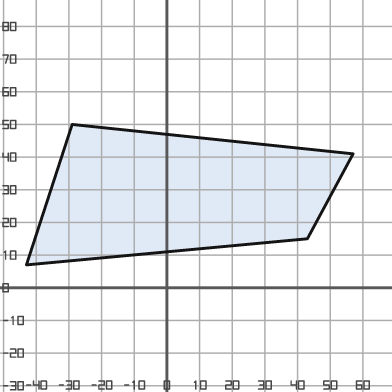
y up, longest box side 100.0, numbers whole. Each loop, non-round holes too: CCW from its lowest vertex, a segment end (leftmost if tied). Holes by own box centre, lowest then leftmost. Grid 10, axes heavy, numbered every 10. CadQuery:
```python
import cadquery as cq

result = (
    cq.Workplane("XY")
    .moveTo(-43.0, 7.0)
    .lineTo(43.0, 15.0)
    .lineTo(57.0, 41.0)
    .lineTo(-29.0, 50.0)
    .close()
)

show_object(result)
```